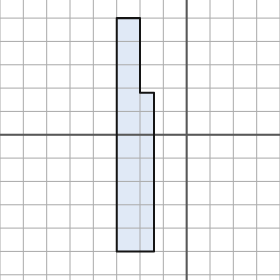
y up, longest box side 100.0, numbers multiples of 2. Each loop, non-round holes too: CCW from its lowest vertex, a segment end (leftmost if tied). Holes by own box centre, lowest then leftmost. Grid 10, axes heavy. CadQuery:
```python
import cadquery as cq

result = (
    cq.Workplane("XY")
    .moveTo(-30.0, -50.0)
    .lineTo(-14.0, -50.0)
    .lineTo(-14.0, 18.0)
    .lineTo(-20.0, 18.0)
    .lineTo(-20.0, 50.0)
    .lineTo(-30.0, 50.0)
    .close()
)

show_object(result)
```